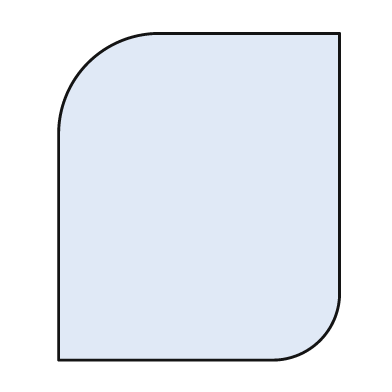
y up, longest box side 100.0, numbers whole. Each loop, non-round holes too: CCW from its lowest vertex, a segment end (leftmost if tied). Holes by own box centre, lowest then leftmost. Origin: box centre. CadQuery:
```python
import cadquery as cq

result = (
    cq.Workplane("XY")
    .moveTo(-43.0, -50.0)
    .lineTo(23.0, -50.0)
    .threePointArc((37.0, -44.0), (43.0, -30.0))
    .lineTo(43.0, 50.0)
    .lineTo(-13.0, 50.0)
    .threePointArc((-34.0, 41.0), (-43.0, 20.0))
    .close()
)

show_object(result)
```